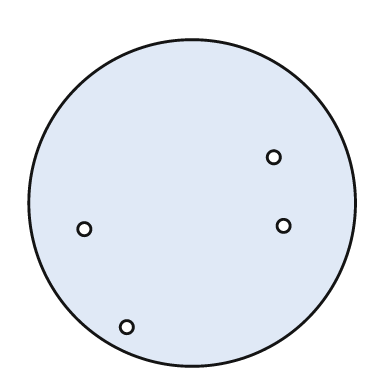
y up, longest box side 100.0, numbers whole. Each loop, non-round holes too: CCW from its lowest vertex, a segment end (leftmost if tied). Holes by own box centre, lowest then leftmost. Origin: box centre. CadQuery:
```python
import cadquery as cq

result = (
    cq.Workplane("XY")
    .moveTo(0.0, 0.0)
    .circle(50.0)
    .moveTo(-20.0, -38.0)
    .circle(2.0)
    .moveTo(-33.0, -8.0)
    .circle(2.0)
    .moveTo(28.0, -7.0)
    .circle(2.0)
    .moveTo(25.0, 14.0)
    .circle(2.0)
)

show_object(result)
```